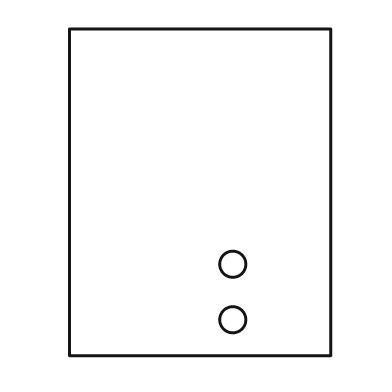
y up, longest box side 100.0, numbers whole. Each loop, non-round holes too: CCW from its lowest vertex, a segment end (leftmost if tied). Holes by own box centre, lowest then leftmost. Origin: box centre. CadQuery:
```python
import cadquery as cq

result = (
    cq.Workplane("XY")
    .moveTo(-40.0, -50.0)
    .lineTo(40.0, -50.0)
    .lineTo(40.0, 50.0)
    .lineTo(-40.0, 50.0)
    .close()
    .moveTo(10.0, -39.0)
    .circle(4.0)
    .moveTo(10.0, -22.0)
    .circle(4.0)
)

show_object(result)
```